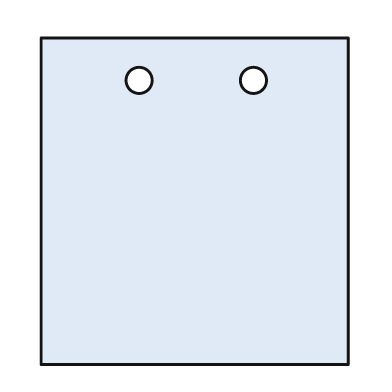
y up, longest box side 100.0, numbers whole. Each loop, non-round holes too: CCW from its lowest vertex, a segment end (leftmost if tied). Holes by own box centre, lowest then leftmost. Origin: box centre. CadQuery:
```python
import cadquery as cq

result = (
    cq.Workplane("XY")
    .moveTo(-47.0, -50.0)
    .lineTo(47.0, -50.0)
    .lineTo(47.0, 50.0)
    .lineTo(-47.0, 50.0)
    .close()
    .moveTo(-17.0, 37.0)
    .circle(4.0)
    .moveTo(18.0, 37.0)
    .circle(4.0)
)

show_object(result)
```